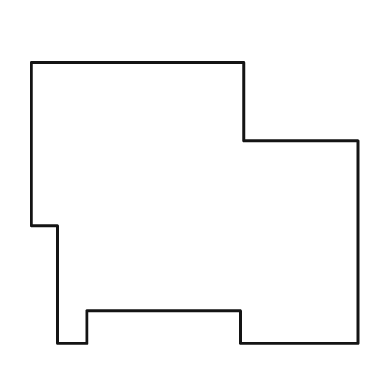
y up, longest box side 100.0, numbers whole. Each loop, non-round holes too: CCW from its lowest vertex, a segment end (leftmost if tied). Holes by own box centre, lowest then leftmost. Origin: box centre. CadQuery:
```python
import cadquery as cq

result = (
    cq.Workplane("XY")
    .moveTo(-42.0, -43.0)
    .lineTo(-33.0, -43.0)
    .lineTo(-33.0, -33.0)
    .lineTo(14.0, -33.0)
    .lineTo(14.0, -43.0)
    .lineTo(50.0, -43.0)
    .lineTo(50.0, 19.0)
    .lineTo(15.0, 19.0)
    .lineTo(15.0, 43.0)
    .lineTo(-50.0, 43.0)
    .lineTo(-50.0, -7.0)
    .lineTo(-42.0, -7.0)
    .close()
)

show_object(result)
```